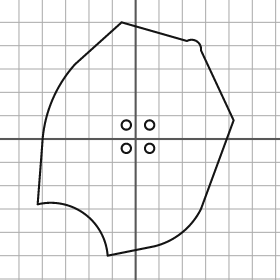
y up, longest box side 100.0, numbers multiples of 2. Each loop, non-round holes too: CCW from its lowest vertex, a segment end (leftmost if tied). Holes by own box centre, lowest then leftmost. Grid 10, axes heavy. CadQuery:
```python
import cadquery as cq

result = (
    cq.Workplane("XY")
    .moveTo(-12.0, -50.0)
    .lineTo(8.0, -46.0)
    .threePointArc((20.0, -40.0), (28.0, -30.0))
    .lineTo(42.0, 8.0)
    .lineTo(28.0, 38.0)
    .threePointArc((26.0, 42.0), (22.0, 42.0))
    .lineTo(-6.0, 50.0)
    .lineTo(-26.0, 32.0)
    .threePointArc((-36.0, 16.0), (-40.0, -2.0))
    .lineTo(-42.0, -28.0)
    .threePointArc((-22.0, -32.0), (-12.0, -50.0))
    .close()
    .moveTo(-4.0, -4.0)
    .circle(2.0)
    .moveTo(6.0, -4.0)
    .circle(2.0)
    .moveTo(-4.0, 6.0)
    .circle(2.0)
    .moveTo(6.0, 6.0)
    .circle(2.0)
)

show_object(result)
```